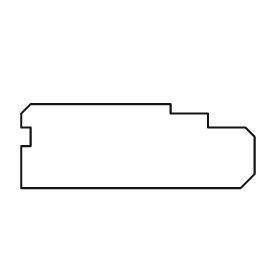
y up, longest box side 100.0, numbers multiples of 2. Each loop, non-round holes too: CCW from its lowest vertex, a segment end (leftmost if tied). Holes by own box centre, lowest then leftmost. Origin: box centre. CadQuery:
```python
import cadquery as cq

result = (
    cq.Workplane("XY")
    .moveTo(-50.0, -18.0)
    .lineTo(44.0, -18.0)
    .lineTo(50.0, -12.0)
    .lineTo(50.0, 4.0)
    .lineTo(46.0, 8.0)
    .lineTo(30.0, 8.0)
    .lineTo(30.0, 14.0)
    .lineTo(14.0, 14.0)
    .lineTo(14.0, 18.0)
    .lineTo(-46.0, 18.0)
    .lineTo(-50.0, 14.0)
    .lineTo(-50.0, 8.0)
    .lineTo(-46.0, 8.0)
    .lineTo(-46.0, 0.0)
    .lineTo(-50.0, 0.0)
    .close()
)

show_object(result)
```